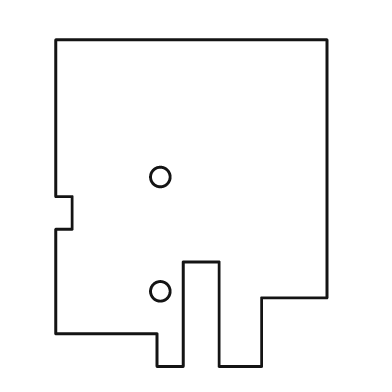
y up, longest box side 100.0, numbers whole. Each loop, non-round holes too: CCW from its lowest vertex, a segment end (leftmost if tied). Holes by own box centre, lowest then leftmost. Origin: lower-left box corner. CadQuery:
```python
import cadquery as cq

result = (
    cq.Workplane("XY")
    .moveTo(31.0, 0.0)
    .lineTo(39.0, 0.0)
    .lineTo(39.0, 32.0)
    .lineTo(50.0, 32.0)
    .lineTo(50.0, 0.0)
    .lineTo(63.0, 0.0)
    .lineTo(63.0, 21.0)
    .lineTo(83.0, 21.0)
    .lineTo(83.0, 100.0)
    .lineTo(0.0, 100.0)
    .lineTo(0.0, 52.0)
    .lineTo(5.0, 52.0)
    .lineTo(5.0, 42.0)
    .lineTo(0.0, 42.0)
    .lineTo(0.0, 10.0)
    .lineTo(31.0, 10.0)
    .close()
    .moveTo(32.0, 23.0)
    .circle(3.0)
    .moveTo(32.0, 58.0)
    .circle(3.0)
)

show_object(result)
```